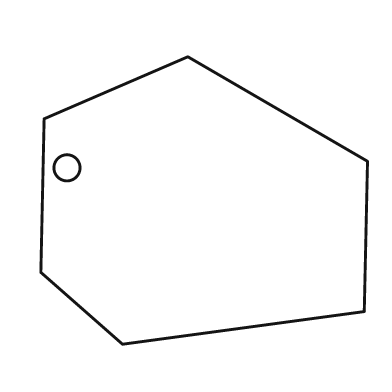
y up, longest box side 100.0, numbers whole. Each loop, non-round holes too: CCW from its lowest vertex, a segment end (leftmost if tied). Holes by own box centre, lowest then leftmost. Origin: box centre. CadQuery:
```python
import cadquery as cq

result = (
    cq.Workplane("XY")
    .moveTo(-25.0, -44.0)
    .lineTo(49.0, -34.0)
    .lineTo(50.0, 12.0)
    .lineTo(-5.0, 44.0)
    .lineTo(-49.0, 25.0)
    .lineTo(-50.0, -22.0)
    .close()
    .moveTo(-42.0, 10.0)
    .circle(4.0)
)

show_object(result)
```